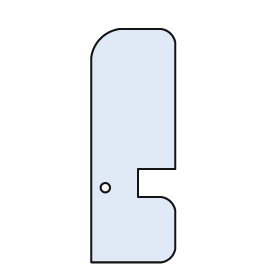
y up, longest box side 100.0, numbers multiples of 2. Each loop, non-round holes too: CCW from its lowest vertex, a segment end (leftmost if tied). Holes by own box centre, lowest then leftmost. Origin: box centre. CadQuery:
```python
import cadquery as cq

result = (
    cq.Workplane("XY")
    .moveTo(-18.0, -50.0)
    .lineTo(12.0, -50.0)
    .threePointArc((16.0, -48.0), (18.0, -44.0))
    .lineTo(18.0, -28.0)
    .threePointArc((16.0, -24.0), (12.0, -22.0))
    .lineTo(2.0, -22.0)
    .lineTo(2.0, -10.0)
    .lineTo(18.0, -10.0)
    .lineTo(18.0, 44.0)
    .threePointArc((16.0, 48.0), (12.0, 50.0))
    .lineTo(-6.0, 50.0)
    .threePointArc((-14.0, 46.0), (-18.0, 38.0))
    .close()
    .moveTo(-12.0, -18.0)
    .circle(2.0)
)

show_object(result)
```